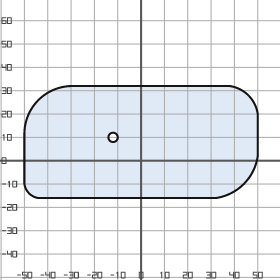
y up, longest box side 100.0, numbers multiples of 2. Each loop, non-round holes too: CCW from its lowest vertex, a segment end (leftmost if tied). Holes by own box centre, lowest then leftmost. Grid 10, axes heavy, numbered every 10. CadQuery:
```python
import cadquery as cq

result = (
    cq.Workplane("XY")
    .moveTo(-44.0, -16.0)
    .lineTo(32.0, -16.0)
    .threePointArc((44.0, -10.0), (50.0, 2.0))
    .lineTo(50.0, 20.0)
    .threePointArc((46.0, 28.0), (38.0, 32.0))
    .lineTo(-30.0, 32.0)
    .threePointArc((-44.0, 26.0), (-50.0, 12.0))
    .lineTo(-50.0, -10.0)
    .threePointArc((-48.0, -14.0), (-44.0, -16.0))
    .close()
    .moveTo(-12.0, 10.0)
    .circle(2.0)
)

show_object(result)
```